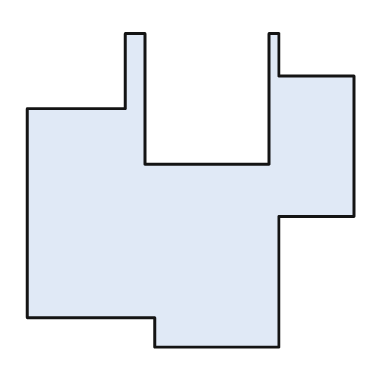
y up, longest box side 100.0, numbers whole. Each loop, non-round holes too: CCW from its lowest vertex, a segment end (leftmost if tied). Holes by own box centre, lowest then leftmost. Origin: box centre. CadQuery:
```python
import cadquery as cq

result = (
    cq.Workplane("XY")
    .moveTo(-11.0, -48.0)
    .lineTo(27.0, -48.0)
    .lineTo(27.0, -8.0)
    .lineTo(50.0, -8.0)
    .lineTo(50.0, 35.0)
    .lineTo(27.0, 35.0)
    .lineTo(27.0, 48.0)
    .lineTo(24.0, 48.0)
    .lineTo(24.0, 8.0)
    .lineTo(-14.0, 8.0)
    .lineTo(-14.0, 48.0)
    .lineTo(-20.0, 48.0)
    .lineTo(-20.0, 25.0)
    .lineTo(-50.0, 25.0)
    .lineTo(-50.0, -39.0)
    .lineTo(-11.0, -39.0)
    .close()
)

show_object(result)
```